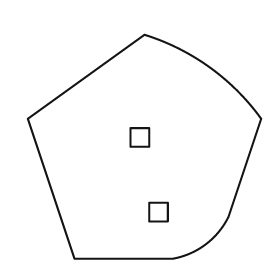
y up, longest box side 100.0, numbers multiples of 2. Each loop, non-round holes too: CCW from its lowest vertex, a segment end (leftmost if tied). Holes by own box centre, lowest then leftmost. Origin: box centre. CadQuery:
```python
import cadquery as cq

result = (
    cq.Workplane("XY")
    .moveTo(-30.0, -48.0)
    .lineTo(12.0, -48.0)
    .threePointArc((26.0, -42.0), (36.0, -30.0))
    .lineTo(50.0, 12.0)
    .threePointArc((28.0, 34.0), (0.0, 48.0))
    .lineTo(-50.0, 12.0)
    .close()
    .moveTo(2.0, -32.0)
    .lineTo(10.0, -32.0)
    .lineTo(10.0, -24.0)
    .lineTo(2.0, -24.0)
    .close()
    .moveTo(-6.0, 0.0)
    .lineTo(2.0, 0.0)
    .lineTo(2.0, 8.0)
    .lineTo(-6.0, 8.0)
    .close()
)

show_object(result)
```